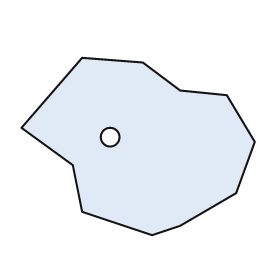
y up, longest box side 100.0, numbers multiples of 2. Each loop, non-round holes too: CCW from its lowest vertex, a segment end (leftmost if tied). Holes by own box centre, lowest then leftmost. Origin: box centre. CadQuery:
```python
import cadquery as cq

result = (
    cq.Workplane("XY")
    .moveTo(6.0, -38.0)
    .lineTo(18.0, -34.0)
    .lineTo(42.0, -20.0)
    .lineTo(50.0, 2.0)
    .lineTo(38.0, 22.0)
    .lineTo(18.0, 24.0)
    .lineTo(2.0, 36.0)
    .lineTo(-24.0, 38.0)
    .lineTo(-50.0, 8.0)
    .lineTo(-28.0, -8.0)
    .lineTo(-24.0, -28.0)
    .close()
    .moveTo(-12.0, 4.0)
    .circle(4.0)
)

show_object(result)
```